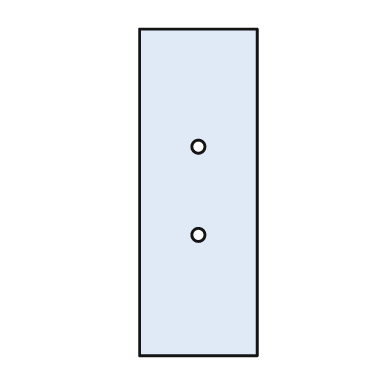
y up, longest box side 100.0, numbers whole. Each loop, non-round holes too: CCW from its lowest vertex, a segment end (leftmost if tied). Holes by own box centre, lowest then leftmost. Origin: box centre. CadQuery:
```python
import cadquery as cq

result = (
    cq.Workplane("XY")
    .moveTo(-18.0, -50.0)
    .lineTo(18.0, -50.0)
    .lineTo(18.0, 50.0)
    .lineTo(-18.0, 50.0)
    .close()
    .moveTo(0.0, -13.0)
    .circle(2.0)
    .moveTo(0.0, 14.0)
    .circle(2.0)
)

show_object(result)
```